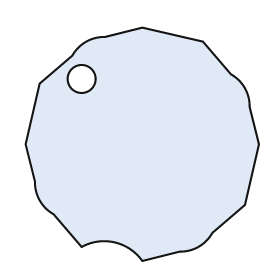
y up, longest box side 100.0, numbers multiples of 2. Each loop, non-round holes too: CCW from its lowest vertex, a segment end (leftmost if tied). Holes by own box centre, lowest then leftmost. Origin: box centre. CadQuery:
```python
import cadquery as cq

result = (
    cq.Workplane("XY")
    .moveTo(0.0, -50.0)
    .lineTo(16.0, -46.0)
    .threePointArc((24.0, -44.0), (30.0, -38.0))
    .lineTo(44.0, -26.0)
    .lineTo(50.0, 0.0)
    .lineTo(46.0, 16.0)
    .threePointArc((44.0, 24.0), (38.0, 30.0))
    .lineTo(26.0, 44.0)
    .lineTo(0.0, 50.0)
    .lineTo(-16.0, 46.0)
    .threePointArc((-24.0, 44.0), (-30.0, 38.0))
    .lineTo(-44.0, 26.0)
    .lineTo(-50.0, 0.0)
    .lineTo(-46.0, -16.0)
    .threePointArc((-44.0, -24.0), (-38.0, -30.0))
    .lineTo(-26.0, -44.0)
    .threePointArc((-12.0, -42.0), (0.0, -50.0))
    .close()
    .moveTo(-26.0, 28.0)
    .circle(6.0)
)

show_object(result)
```